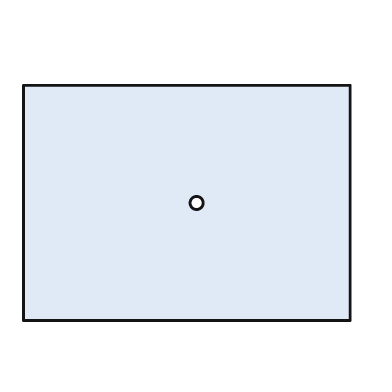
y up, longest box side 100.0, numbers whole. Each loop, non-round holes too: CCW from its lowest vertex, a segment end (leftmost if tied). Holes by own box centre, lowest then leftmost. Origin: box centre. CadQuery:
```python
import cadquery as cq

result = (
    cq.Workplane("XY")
    .moveTo(-50.0, -36.0)
    .lineTo(50.0, -36.0)
    .lineTo(50.0, 36.0)
    .lineTo(-50.0, 36.0)
    .close()
    .moveTo(3.0, 0.0)
    .circle(2.0)
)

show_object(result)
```